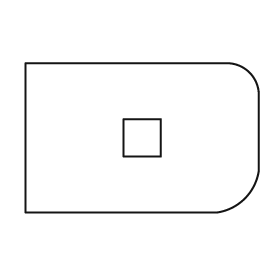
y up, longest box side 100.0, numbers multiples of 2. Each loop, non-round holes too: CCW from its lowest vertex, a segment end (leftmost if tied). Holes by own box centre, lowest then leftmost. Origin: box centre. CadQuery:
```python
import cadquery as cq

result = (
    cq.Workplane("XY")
    .moveTo(-50.0, -32.0)
    .lineTo(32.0, -32.0)
    .threePointArc((44.0, -26.0), (50.0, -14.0))
    .lineTo(50.0, 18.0)
    .threePointArc((46.0, 28.0), (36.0, 32.0))
    .lineTo(-50.0, 32.0)
    .close()
    .moveTo(-8.0, -8.0)
    .lineTo(8.0, -8.0)
    .lineTo(8.0, 8.0)
    .lineTo(-8.0, 8.0)
    .close()
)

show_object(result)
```